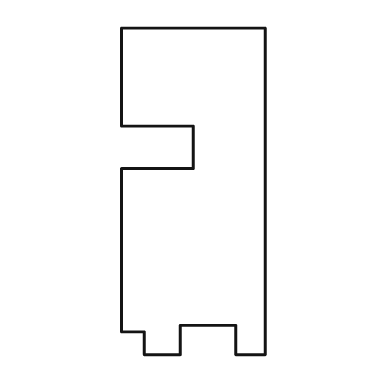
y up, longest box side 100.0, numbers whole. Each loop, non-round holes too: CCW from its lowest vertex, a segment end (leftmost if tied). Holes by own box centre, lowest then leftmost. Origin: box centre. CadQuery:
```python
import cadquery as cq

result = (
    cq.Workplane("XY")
    .moveTo(-15.0, -50.0)
    .lineTo(-4.0, -50.0)
    .lineTo(-4.0, -41.0)
    .lineTo(13.0, -41.0)
    .lineTo(13.0, -50.0)
    .lineTo(22.0, -50.0)
    .lineTo(22.0, 50.0)
    .lineTo(-22.0, 50.0)
    .lineTo(-22.0, 20.0)
    .lineTo(0.0, 20.0)
    .lineTo(0.0, 7.0)
    .lineTo(-22.0, 7.0)
    .lineTo(-22.0, -43.0)
    .lineTo(-15.0, -43.0)
    .close()
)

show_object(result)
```